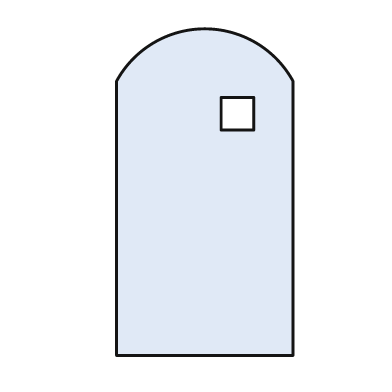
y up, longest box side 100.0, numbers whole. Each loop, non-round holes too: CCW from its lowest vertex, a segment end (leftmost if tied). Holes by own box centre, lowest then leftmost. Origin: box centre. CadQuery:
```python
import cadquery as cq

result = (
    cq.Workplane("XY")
    .moveTo(-27.0, -50.0)
    .lineTo(27.0, -50.0)
    .lineTo(27.0, 34.0)
    .threePointArc((0.0, 50.0), (-27.0, 34.0))
    .close()
    .moveTo(5.0, 19.0)
    .lineTo(15.0, 19.0)
    .lineTo(15.0, 29.0)
    .lineTo(5.0, 29.0)
    .close()
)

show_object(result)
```